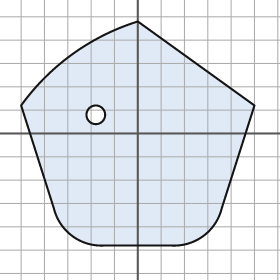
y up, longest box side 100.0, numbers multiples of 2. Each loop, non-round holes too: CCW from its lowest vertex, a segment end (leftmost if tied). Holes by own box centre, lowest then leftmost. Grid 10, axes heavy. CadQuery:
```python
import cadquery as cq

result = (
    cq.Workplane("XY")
    .moveTo(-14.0, -48.0)
    .lineTo(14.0, -48.0)
    .threePointArc((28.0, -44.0), (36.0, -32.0))
    .lineTo(50.0, 12.0)
    .lineTo(0.0, 48.0)
    .threePointArc((-28.0, 34.0), (-50.0, 12.0))
    .lineTo(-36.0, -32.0)
    .threePointArc((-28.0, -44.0), (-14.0, -48.0))
    .close()
    .moveTo(-18.0, 8.0)
    .circle(4.0)
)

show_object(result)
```